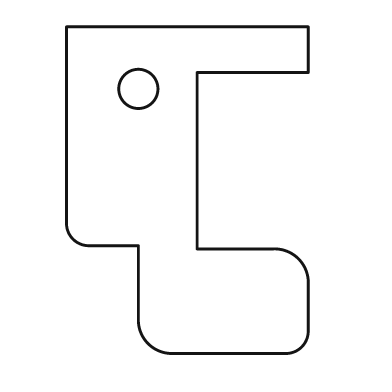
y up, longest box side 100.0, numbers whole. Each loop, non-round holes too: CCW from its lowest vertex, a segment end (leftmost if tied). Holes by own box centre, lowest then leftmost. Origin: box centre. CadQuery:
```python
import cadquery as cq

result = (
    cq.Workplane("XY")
    .moveTo(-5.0, -50.0)
    .lineTo(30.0, -50.0)
    .threePointArc((35.0, -48.0), (37.0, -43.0))
    .lineTo(37.0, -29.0)
    .threePointArc((34.0, -21.0), (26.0, -18.0))
    .lineTo(3.0, -18.0)
    .lineTo(3.0, 36.0)
    .lineTo(37.0, 36.0)
    .lineTo(37.0, 50.0)
    .lineTo(-37.0, 50.0)
    .lineTo(-37.0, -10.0)
    .threePointArc((-35.0, -15.0), (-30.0, -17.0))
    .lineTo(-15.0, -17.0)
    .lineTo(-15.0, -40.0)
    .threePointArc((-12.0, -47.0), (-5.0, -50.0))
    .close()
    .moveTo(-15.0, 31.0)
    .circle(6.0)
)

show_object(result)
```